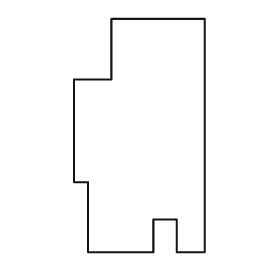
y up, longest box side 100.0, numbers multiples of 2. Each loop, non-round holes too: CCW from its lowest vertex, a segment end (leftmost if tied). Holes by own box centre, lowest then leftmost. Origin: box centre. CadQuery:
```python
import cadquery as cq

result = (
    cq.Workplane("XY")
    .moveTo(-22.0, -50.0)
    .lineTo(6.0, -50.0)
    .lineTo(6.0, -36.0)
    .lineTo(16.0, -36.0)
    .lineTo(16.0, -50.0)
    .lineTo(28.0, -50.0)
    .lineTo(28.0, 50.0)
    .lineTo(-12.0, 50.0)
    .lineTo(-12.0, 24.0)
    .lineTo(-28.0, 24.0)
    .lineTo(-28.0, -20.0)
    .lineTo(-22.0, -20.0)
    .close()
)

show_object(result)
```